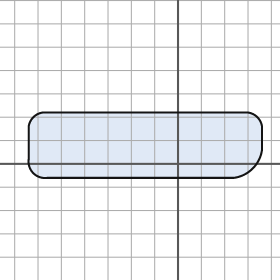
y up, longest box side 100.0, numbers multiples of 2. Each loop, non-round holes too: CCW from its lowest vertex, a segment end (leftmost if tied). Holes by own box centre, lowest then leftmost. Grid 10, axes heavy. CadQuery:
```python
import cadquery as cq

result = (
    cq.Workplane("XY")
    .moveTo(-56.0, -6.0)
    .lineTo(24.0, -6.0)
    .threePointArc((32.0, -2.0), (36.0, 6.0))
    .lineTo(36.0, 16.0)
    .threePointArc((34.0, 20.0), (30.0, 22.0))
    .lineTo(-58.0, 22.0)
    .threePointArc((-62.0, 20.0), (-64.0, 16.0))
    .lineTo(-64.0, 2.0)
    .threePointArc((-62.0, -4.0), (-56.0, -6.0))
    .close()
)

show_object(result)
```